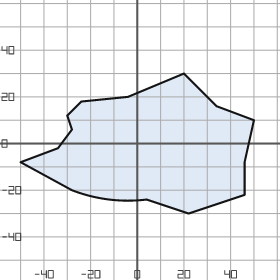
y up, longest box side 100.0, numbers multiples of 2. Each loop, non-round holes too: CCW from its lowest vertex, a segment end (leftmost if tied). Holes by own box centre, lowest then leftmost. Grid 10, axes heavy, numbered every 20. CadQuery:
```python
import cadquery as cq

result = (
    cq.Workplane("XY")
    .moveTo(22.0, -30.0)
    .lineTo(46.0, -22.0)
    .lineTo(46.0, -8.0)
    .lineTo(50.0, 10.0)
    .lineTo(34.0, 16.0)
    .lineTo(20.0, 30.0)
    .lineTo(-4.0, 20.0)
    .lineTo(-24.0, 18.0)
    .lineTo(-30.0, 12.0)
    .lineTo(-28.0, 6.0)
    .lineTo(-34.0, -2.0)
    .lineTo(-50.0, -8.0)
    .lineTo(-28.0, -20.0)
    .threePointArc((-12.0, -24.0), (4.0, -24.0))
    .close()
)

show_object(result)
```